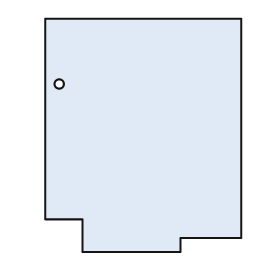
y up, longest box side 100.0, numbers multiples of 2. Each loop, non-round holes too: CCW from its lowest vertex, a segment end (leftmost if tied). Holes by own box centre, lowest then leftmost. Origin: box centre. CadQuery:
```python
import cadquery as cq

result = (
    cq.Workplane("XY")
    .moveTo(-26.0, -50.0)
    .lineTo(16.0, -50.0)
    .lineTo(16.0, -44.0)
    .lineTo(42.0, -44.0)
    .lineTo(42.0, 50.0)
    .lineTo(-42.0, 50.0)
    .lineTo(-42.0, -36.0)
    .lineTo(-26.0, -36.0)
    .close()
    .moveTo(-36.0, 22.0)
    .circle(2.0)
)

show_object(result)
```